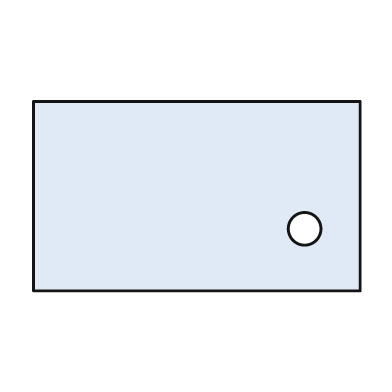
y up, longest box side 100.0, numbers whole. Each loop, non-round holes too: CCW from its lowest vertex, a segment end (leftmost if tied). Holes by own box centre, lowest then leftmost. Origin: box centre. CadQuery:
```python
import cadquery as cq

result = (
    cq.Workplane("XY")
    .moveTo(-50.0, -29.0)
    .lineTo(50.0, -29.0)
    .lineTo(50.0, 29.0)
    .lineTo(-50.0, 29.0)
    .close()
    .moveTo(33.0, -10.0)
    .circle(5.0)
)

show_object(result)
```